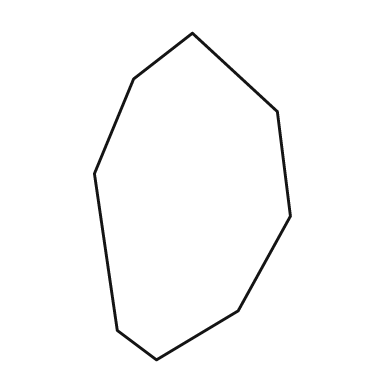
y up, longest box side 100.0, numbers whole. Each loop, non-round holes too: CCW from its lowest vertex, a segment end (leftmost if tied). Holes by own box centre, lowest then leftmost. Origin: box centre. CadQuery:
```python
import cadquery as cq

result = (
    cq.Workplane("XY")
    .moveTo(-11.0, -50.0)
    .lineTo(14.0, -35.0)
    .lineTo(30.0, -6.0)
    .lineTo(26.0, 26.0)
    .lineTo(0.0, 50.0)
    .lineTo(-18.0, 36.0)
    .lineTo(-30.0, 7.0)
    .lineTo(-23.0, -41.0)
    .close()
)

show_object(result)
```